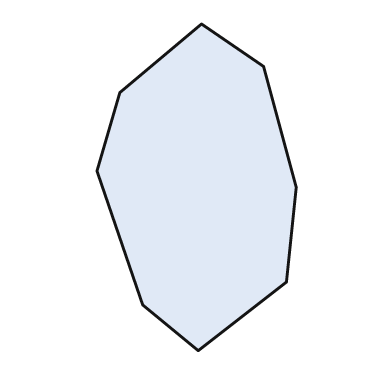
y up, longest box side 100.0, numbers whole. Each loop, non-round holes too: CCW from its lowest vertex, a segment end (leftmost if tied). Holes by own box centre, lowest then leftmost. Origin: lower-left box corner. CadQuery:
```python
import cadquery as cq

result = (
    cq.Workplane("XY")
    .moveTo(31.0, 0.0)
    .lineTo(58.0, 21.0)
    .lineTo(61.0, 50.0)
    .lineTo(51.0, 87.0)
    .lineTo(32.0, 100.0)
    .lineTo(7.0, 79.0)
    .lineTo(0.0, 55.0)
    .lineTo(14.0, 14.0)
    .close()
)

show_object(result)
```